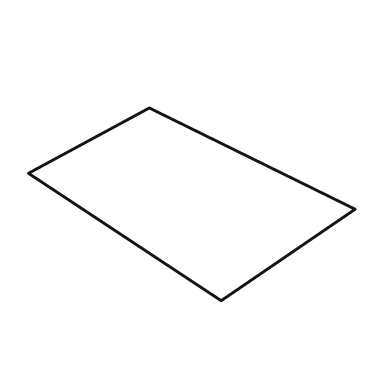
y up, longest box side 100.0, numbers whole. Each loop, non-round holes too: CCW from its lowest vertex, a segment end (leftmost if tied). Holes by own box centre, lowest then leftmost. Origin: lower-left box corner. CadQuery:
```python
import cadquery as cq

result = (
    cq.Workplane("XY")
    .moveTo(59.0, 0.0)
    .lineTo(100.0, 28.0)
    .lineTo(37.0, 59.0)
    .lineTo(0.0, 39.0)
    .close()
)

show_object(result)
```